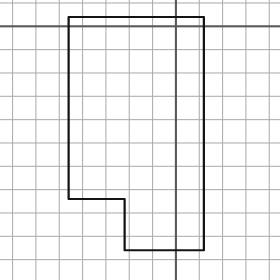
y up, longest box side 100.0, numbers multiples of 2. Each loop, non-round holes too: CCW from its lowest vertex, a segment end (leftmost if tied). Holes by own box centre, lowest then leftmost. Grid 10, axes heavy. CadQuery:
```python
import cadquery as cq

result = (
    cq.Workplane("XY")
    .moveTo(-22.0, -96.0)
    .lineTo(12.0, -96.0)
    .lineTo(12.0, 4.0)
    .lineTo(-46.0, 4.0)
    .lineTo(-46.0, -74.0)
    .lineTo(-22.0, -74.0)
    .close()
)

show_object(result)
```